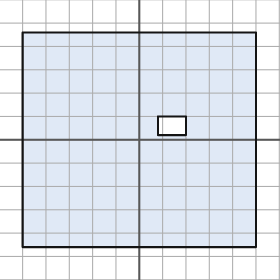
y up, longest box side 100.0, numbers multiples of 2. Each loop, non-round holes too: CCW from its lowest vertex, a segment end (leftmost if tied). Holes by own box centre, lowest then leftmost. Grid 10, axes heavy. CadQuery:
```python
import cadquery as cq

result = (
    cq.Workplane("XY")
    .moveTo(-50.0, -46.0)
    .lineTo(50.0, -46.0)
    .lineTo(50.0, 46.0)
    .lineTo(-50.0, 46.0)
    .close()
    .moveTo(8.0, 2.0)
    .lineTo(20.0, 2.0)
    .lineTo(20.0, 10.0)
    .lineTo(8.0, 10.0)
    .close()
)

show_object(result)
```